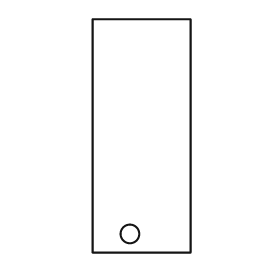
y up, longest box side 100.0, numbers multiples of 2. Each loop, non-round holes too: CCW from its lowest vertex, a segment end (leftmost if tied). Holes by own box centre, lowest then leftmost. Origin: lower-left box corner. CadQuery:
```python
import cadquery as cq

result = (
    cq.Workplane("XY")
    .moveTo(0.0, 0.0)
    .lineTo(42.0, 0.0)
    .lineTo(42.0, 100.0)
    .lineTo(0.0, 100.0)
    .close()
    .moveTo(16.0, 8.0)
    .circle(4.0)
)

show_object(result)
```